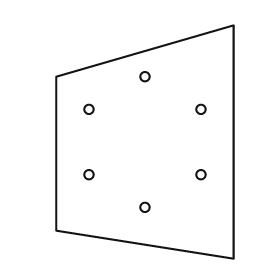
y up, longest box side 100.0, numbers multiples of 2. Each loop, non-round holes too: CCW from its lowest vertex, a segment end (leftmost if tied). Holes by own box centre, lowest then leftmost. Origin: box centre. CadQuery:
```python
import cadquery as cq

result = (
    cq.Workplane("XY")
    .moveTo(38.0, -50.0)
    .lineTo(38.0, 50.0)
    .lineTo(-38.0, 28.0)
    .lineTo(-38.0, -38.0)
    .close()
    .moveTo(0.0, -28.0)
    .circle(2.0)
    .moveTo(-24.0, -14.0)
    .circle(2.0)
    .moveTo(24.0, -14.0)
    .circle(2.0)
    .moveTo(-24.0, 14.0)
    .circle(2.0)
    .moveTo(24.0, 14.0)
    .circle(2.0)
    .moveTo(0.0, 28.0)
    .circle(2.0)
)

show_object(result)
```